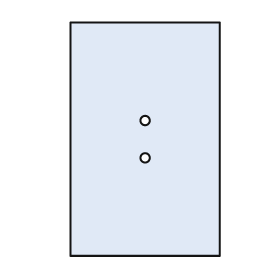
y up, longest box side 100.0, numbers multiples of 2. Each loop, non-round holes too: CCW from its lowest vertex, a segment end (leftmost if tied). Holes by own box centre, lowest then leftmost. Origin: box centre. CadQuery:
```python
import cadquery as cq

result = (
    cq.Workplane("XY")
    .moveTo(-32.0, -50.0)
    .lineTo(32.0, -50.0)
    .lineTo(32.0, 50.0)
    .lineTo(-32.0, 50.0)
    .close()
    .moveTo(0.0, -8.0)
    .circle(2.0)
    .moveTo(0.0, 8.0)
    .circle(2.0)
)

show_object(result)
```